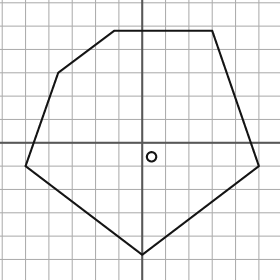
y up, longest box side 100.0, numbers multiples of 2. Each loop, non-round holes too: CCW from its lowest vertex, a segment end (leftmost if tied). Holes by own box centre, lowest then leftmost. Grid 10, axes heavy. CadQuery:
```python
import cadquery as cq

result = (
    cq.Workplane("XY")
    .moveTo(0.0, -48.0)
    .lineTo(50.0, -10.0)
    .lineTo(30.0, 48.0)
    .lineTo(-12.0, 48.0)
    .lineTo(-36.0, 30.0)
    .lineTo(-50.0, -10.0)
    .close()
    .moveTo(4.0, -6.0)
    .circle(2.0)
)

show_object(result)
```